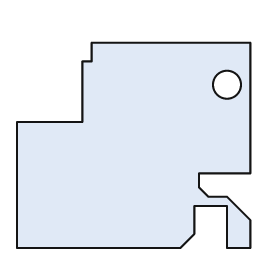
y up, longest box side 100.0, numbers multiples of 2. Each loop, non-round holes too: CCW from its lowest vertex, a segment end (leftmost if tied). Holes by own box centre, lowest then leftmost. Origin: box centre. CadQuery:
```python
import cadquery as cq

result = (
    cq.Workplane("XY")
    .moveTo(-50.0, -44.0)
    .lineTo(20.0, -44.0)
    .lineTo(26.0, -38.0)
    .lineTo(26.0, -26.0)
    .lineTo(40.0, -26.0)
    .lineTo(40.0, -44.0)
    .lineTo(50.0, -44.0)
    .lineTo(50.0, -32.0)
    .lineTo(40.0, -22.0)
    .lineTo(32.0, -22.0)
    .lineTo(28.0, -18.0)
    .lineTo(28.0, -12.0)
    .lineTo(50.0, -12.0)
    .lineTo(50.0, 44.0)
    .lineTo(-18.0, 44.0)
    .lineTo(-18.0, 36.0)
    .lineTo(-22.0, 36.0)
    .lineTo(-22.0, 10.0)
    .lineTo(-50.0, 10.0)
    .close()
    .moveTo(40.0, 26.0)
    .circle(6.0)
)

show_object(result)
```